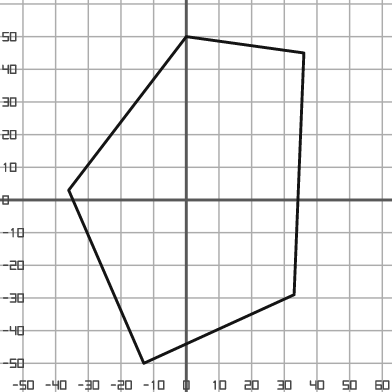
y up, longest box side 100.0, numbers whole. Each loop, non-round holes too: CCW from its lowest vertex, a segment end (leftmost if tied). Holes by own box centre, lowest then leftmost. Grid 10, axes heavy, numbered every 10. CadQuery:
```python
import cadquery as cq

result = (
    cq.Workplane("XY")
    .moveTo(-13.0, -50.0)
    .lineTo(33.0, -29.0)
    .lineTo(36.0, 45.0)
    .lineTo(0.0, 50.0)
    .lineTo(-36.0, 3.0)
    .close()
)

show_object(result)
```